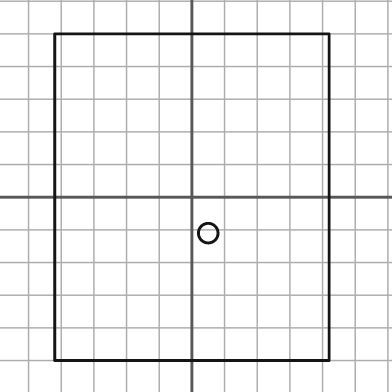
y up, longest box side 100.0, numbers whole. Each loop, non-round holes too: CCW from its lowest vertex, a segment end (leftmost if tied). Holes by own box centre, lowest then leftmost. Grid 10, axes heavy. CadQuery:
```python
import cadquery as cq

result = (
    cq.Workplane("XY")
    .moveTo(-42.0, -50.0)
    .lineTo(42.0, -50.0)
    .lineTo(42.0, 50.0)
    .lineTo(-42.0, 50.0)
    .close()
    .moveTo(5.0, -11.0)
    .circle(3.0)
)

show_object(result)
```